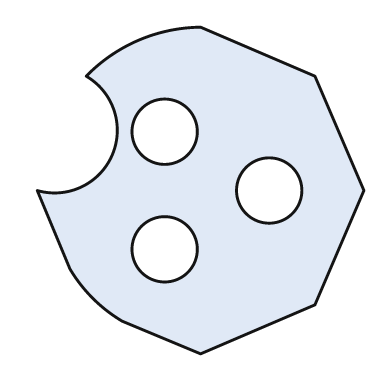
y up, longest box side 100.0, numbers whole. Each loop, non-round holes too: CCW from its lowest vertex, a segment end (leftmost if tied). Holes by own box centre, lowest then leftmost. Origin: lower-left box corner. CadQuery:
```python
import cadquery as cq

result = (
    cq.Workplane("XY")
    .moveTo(50.0, 0.0)
    .lineTo(85.0, 15.0)
    .lineTo(100.0, 50.0)
    .lineTo(85.0, 85.0)
    .lineTo(50.0, 100.0)
    .threePointArc((31.0, 96.0), (15.0, 85.0))
    .threePointArc((23.0, 61.0), (0.0, 50.0))
    .lineTo(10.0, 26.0)
    .threePointArc((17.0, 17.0), (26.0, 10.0))
    .close()
    .moveTo(39.0, 32.0)
    .circle(10.0)
    .moveTo(71.0, 50.0)
    .circle(10.0)
    .moveTo(39.0, 68.0)
    .circle(10.0)
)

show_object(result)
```